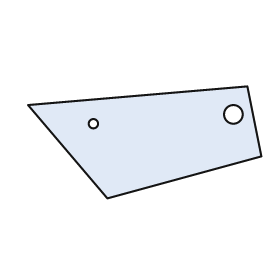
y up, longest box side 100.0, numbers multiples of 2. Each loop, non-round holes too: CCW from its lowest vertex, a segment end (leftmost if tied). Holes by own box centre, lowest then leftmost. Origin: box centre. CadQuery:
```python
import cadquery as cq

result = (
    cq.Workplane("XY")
    .moveTo(-16.0, -24.0)
    .lineTo(50.0, -6.0)
    .lineTo(44.0, 24.0)
    .lineTo(-50.0, 16.0)
    .close()
    .moveTo(-22.0, 8.0)
    .circle(2.0)
    .moveTo(38.0, 12.0)
    .circle(4.0)
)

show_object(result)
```